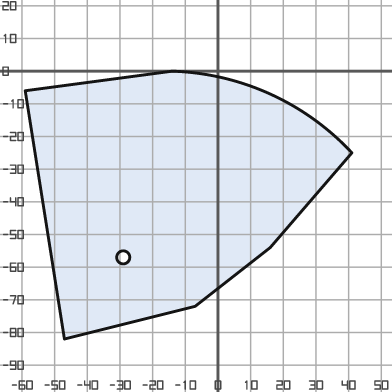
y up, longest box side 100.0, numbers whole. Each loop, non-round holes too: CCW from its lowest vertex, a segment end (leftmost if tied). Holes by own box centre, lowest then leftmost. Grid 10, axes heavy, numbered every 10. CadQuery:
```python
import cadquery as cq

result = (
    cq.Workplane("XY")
    .moveTo(-47.0, -82.0)
    .lineTo(-7.0, -72.0)
    .lineTo(16.0, -54.0)
    .lineTo(41.0, -25.0)
    .threePointArc((16.0, -7.0), (-14.0, 0.0))
    .lineTo(-59.0, -6.0)
    .close()
    .moveTo(-29.0, -57.0)
    .circle(2.0)
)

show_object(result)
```